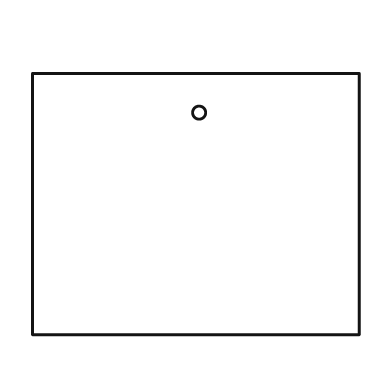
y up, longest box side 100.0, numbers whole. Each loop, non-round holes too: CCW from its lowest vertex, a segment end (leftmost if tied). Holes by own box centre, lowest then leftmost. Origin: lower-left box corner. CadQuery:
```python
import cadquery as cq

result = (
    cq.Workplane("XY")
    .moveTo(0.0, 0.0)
    .lineTo(100.0, 0.0)
    .lineTo(100.0, 80.0)
    .lineTo(0.0, 80.0)
    .close()
    .moveTo(51.0, 68.0)
    .circle(2.0)
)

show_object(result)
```